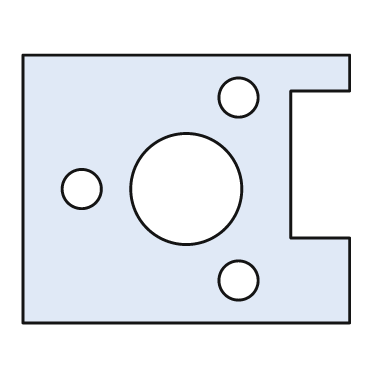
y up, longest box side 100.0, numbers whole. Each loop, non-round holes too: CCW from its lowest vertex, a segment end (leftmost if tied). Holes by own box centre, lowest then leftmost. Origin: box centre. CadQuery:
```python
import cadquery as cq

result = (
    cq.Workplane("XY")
    .moveTo(-50.0, -41.0)
    .lineTo(50.0, -41.0)
    .lineTo(50.0, -15.0)
    .lineTo(32.0, -15.0)
    .lineTo(32.0, 30.0)
    .lineTo(50.0, 30.0)
    .lineTo(50.0, 41.0)
    .lineTo(-50.0, 41.0)
    .close()
    .moveTo(16.0, -28.0)
    .circle(6.0)
    .moveTo(-32.0, 0.0)
    .circle(6.0)
    .moveTo(0.0, 0.0)
    .circle(17.0)
    .moveTo(16.0, 28.0)
    .circle(6.0)
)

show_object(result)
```